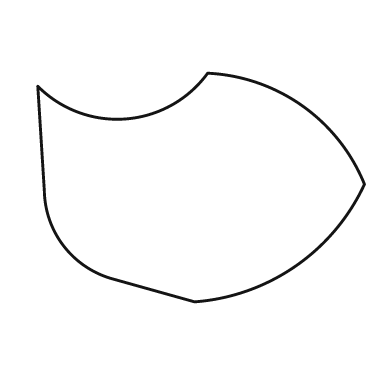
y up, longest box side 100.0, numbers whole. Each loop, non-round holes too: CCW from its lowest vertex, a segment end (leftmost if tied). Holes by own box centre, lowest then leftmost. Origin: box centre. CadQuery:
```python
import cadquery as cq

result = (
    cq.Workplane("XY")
    .moveTo(-2.0, -35.0)
    .threePointArc((29.0, -24.0), (50.0, 1.0))
    .threePointArc((31.0, 25.0), (2.0, 35.0))
    .threePointArc((-23.0, 21.0), (-50.0, 31.0))
    .lineTo(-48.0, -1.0)
    .threePointArc((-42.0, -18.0), (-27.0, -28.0))
    .close()
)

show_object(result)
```